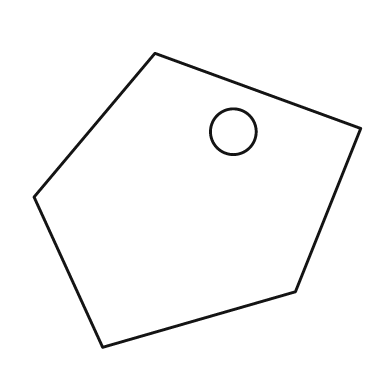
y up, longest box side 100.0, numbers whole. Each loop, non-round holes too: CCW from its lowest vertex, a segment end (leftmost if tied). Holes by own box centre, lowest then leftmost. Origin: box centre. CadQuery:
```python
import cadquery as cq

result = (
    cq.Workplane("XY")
    .moveTo(-29.0, -45.0)
    .lineTo(30.0, -28.0)
    .lineTo(50.0, 22.0)
    .lineTo(-13.0, 45.0)
    .lineTo(-50.0, 1.0)
    .close()
    .moveTo(11.0, 21.0)
    .circle(7.0)
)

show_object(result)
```